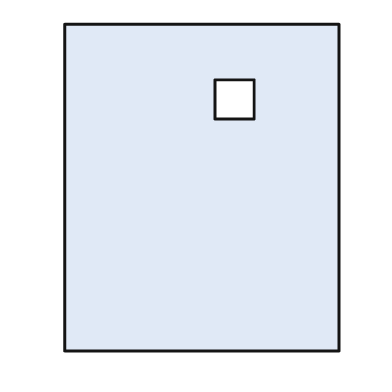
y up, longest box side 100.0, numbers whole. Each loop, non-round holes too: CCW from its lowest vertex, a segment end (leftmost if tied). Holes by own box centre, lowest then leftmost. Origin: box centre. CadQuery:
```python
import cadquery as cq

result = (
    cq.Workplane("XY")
    .moveTo(-42.0, -50.0)
    .lineTo(42.0, -50.0)
    .lineTo(42.0, 50.0)
    .lineTo(-42.0, 50.0)
    .close()
    .moveTo(4.0, 21.0)
    .lineTo(16.0, 21.0)
    .lineTo(16.0, 33.0)
    .lineTo(4.0, 33.0)
    .close()
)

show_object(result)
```